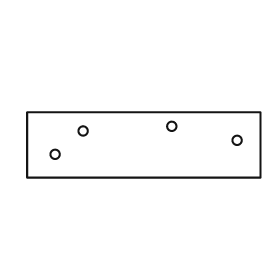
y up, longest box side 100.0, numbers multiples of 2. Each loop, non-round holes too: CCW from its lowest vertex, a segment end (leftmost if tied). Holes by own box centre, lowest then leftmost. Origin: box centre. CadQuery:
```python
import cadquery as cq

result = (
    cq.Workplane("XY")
    .moveTo(-50.0, -14.0)
    .lineTo(50.0, -14.0)
    .lineTo(50.0, 14.0)
    .lineTo(-50.0, 14.0)
    .close()
    .moveTo(-38.0, -4.0)
    .circle(2.0)
    .moveTo(40.0, 2.0)
    .circle(2.0)
    .moveTo(-26.0, 6.0)
    .circle(2.0)
    .moveTo(12.0, 8.0)
    .circle(2.0)
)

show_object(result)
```